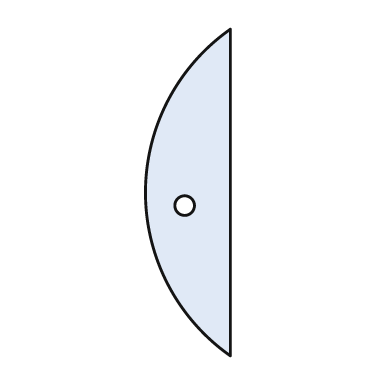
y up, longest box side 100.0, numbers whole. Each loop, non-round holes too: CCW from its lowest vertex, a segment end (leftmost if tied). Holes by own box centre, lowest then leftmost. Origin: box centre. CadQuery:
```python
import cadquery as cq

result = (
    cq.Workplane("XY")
    .moveTo(13.0, -50.0)
    .lineTo(13.0, 50.0)
    .threePointArc((-13.0, 0.0), (13.0, -50.0))
    .close()
    .moveTo(-1.0, -4.0)
    .circle(3.0)
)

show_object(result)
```